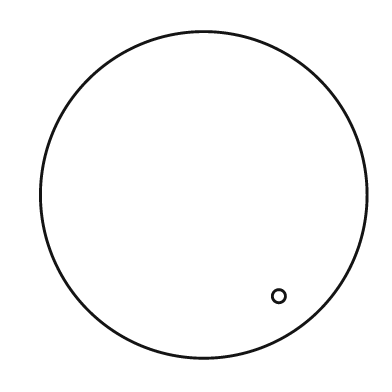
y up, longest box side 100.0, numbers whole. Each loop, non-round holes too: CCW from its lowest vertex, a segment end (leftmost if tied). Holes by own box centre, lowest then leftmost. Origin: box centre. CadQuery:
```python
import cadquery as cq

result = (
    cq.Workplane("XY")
    .moveTo(0.0, 0.0)
    .circle(50.0)
    .moveTo(23.0, -31.0)
    .circle(2.0)
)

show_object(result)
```